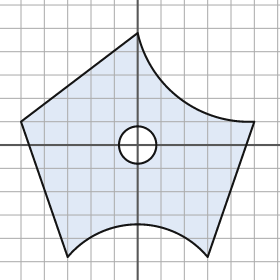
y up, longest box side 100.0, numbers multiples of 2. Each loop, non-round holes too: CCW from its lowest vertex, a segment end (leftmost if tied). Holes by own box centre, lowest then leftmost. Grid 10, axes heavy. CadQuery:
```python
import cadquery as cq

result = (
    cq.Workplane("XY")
    .moveTo(-30.0, -48.0)
    .threePointArc((0.0, -34.0), (30.0, -48.0))
    .lineTo(50.0, 10.0)
    .threePointArc((18.0, 20.0), (0.0, 48.0))
    .lineTo(-50.0, 10.0)
    .close()
    .moveTo(0.0, 0.0)
    .circle(8.0)
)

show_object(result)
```